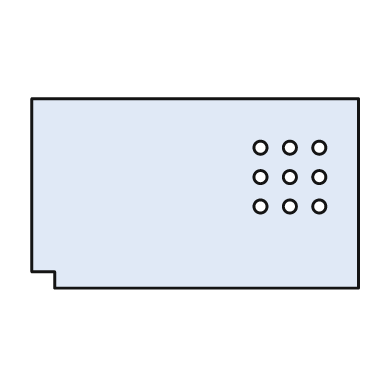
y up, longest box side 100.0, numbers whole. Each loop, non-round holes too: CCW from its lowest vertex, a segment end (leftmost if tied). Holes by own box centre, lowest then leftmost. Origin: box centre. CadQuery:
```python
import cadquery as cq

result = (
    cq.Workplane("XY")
    .moveTo(-43.0, -29.0)
    .lineTo(50.0, -29.0)
    .lineTo(50.0, 29.0)
    .lineTo(-50.0, 29.0)
    .lineTo(-50.0, -24.0)
    .lineTo(-43.0, -24.0)
    .close()
    .moveTo(20.0, -4.0)
    .circle(2.0)
    .moveTo(29.0, -4.0)
    .circle(2.0)
    .moveTo(38.0, -4.0)
    .circle(2.0)
    .moveTo(20.0, 5.0)
    .circle(2.0)
    .moveTo(29.0, 5.0)
    .circle(2.0)
    .moveTo(38.0, 5.0)
    .circle(2.0)
    .moveTo(20.0, 14.0)
    .circle(2.0)
    .moveTo(29.0, 14.0)
    .circle(2.0)
    .moveTo(38.0, 14.0)
    .circle(2.0)
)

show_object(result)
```